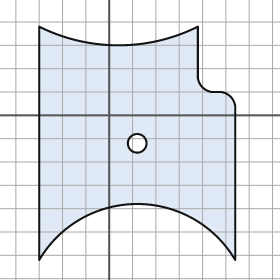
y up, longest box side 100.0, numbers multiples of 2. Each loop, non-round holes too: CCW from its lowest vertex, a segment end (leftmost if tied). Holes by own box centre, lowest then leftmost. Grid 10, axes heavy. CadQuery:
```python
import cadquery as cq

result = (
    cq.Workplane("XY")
    .moveTo(-30.0, -62.0)
    .threePointArc((12.0, -38.0), (54.0, -62.0))
    .lineTo(54.0, 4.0)
    .threePointArc((52.0, 8.0), (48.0, 10.0))
    .lineTo(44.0, 10.0)
    .threePointArc((40.0, 12.0), (38.0, 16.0))
    .lineTo(38.0, 38.0)
    .threePointArc((4.0, 30.0), (-30.0, 38.0))
    .close()
    .moveTo(12.0, -12.0)
    .circle(4.0)
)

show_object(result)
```